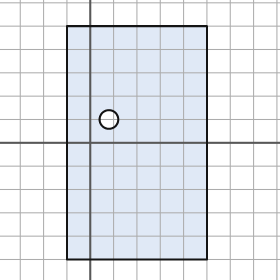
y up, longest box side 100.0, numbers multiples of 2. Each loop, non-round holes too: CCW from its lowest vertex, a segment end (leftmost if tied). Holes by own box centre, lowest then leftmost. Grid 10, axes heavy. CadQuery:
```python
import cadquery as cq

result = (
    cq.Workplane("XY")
    .moveTo(-10.0, -50.0)
    .lineTo(50.0, -50.0)
    .lineTo(50.0, 50.0)
    .lineTo(-10.0, 50.0)
    .close()
    .moveTo(8.0, 10.0)
    .circle(4.0)
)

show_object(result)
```